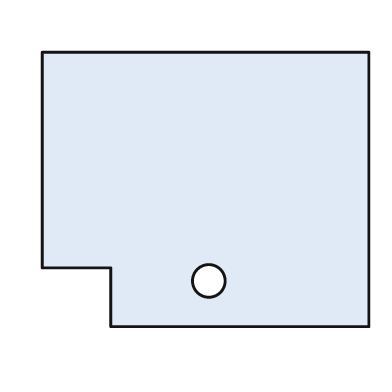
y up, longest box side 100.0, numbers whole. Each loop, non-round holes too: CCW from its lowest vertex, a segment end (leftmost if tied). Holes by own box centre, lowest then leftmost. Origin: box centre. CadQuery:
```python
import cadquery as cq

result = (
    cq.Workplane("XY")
    .moveTo(-29.0, -42.0)
    .lineTo(50.0, -42.0)
    .lineTo(50.0, 42.0)
    .lineTo(-50.0, 42.0)
    .lineTo(-50.0, -24.0)
    .lineTo(-29.0, -24.0)
    .close()
    .moveTo(1.0, -28.0)
    .circle(5.0)
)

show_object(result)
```